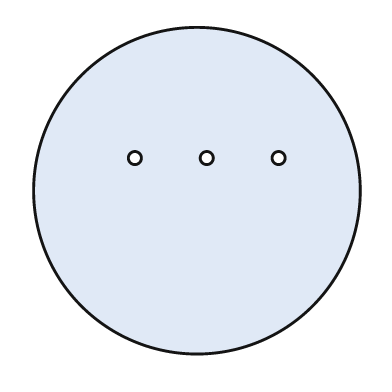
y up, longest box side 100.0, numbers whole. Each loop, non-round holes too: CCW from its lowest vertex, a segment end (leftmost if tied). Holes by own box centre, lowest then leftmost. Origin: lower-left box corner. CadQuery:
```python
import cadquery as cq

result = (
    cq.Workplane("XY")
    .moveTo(50.0, 50.0)
    .circle(50.0)
    .moveTo(31.0, 60.0)
    .circle(2.0)
    .moveTo(53.0, 60.0)
    .circle(2.0)
    .moveTo(75.0, 60.0)
    .circle(2.0)
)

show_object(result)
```